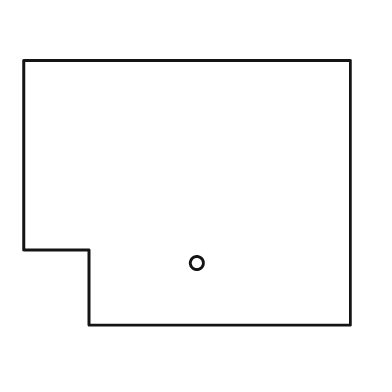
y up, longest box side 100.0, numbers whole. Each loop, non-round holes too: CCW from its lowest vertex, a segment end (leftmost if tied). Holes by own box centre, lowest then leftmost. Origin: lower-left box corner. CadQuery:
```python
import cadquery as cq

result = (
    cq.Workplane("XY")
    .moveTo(20.0, 0.0)
    .lineTo(100.0, 0.0)
    .lineTo(100.0, 81.0)
    .lineTo(0.0, 81.0)
    .lineTo(0.0, 23.0)
    .lineTo(20.0, 23.0)
    .close()
    .moveTo(53.0, 19.0)
    .circle(2.0)
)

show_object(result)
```